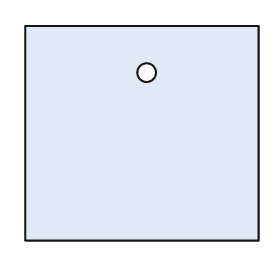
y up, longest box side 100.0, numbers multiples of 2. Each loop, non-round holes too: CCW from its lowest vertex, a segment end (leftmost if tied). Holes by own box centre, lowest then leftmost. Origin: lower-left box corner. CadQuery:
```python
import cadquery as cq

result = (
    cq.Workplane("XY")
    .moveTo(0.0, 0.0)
    .lineTo(100.0, 0.0)
    .lineTo(100.0, 92.0)
    .lineTo(0.0, 92.0)
    .close()
    .moveTo(52.0, 72.0)
    .circle(4.0)
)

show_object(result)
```